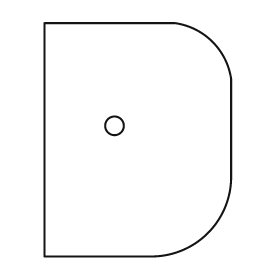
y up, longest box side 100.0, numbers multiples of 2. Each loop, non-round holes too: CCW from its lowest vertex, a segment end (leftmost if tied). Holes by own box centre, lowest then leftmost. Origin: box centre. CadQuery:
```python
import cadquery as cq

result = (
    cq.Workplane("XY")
    .moveTo(-40.0, -50.0)
    .lineTo(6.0, -50.0)
    .threePointArc((30.0, -40.0), (40.0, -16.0))
    .lineTo(40.0, 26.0)
    .threePointArc((32.0, 42.0), (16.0, 50.0))
    .lineTo(-40.0, 50.0)
    .close()
    .moveTo(-10.0, 6.0)
    .circle(4.0)
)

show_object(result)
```